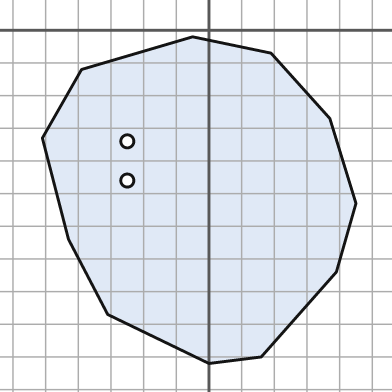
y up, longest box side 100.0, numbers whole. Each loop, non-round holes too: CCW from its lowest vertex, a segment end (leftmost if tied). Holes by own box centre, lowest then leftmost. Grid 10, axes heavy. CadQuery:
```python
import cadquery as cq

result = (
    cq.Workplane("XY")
    .moveTo(0.0, -102.0)
    .lineTo(16.0, -100.0)
    .lineTo(39.0, -74.0)
    .lineTo(45.0, -53.0)
    .lineTo(37.0, -27.0)
    .lineTo(19.0, -7.0)
    .lineTo(-5.0, -2.0)
    .lineTo(-39.0, -12.0)
    .lineTo(-51.0, -33.0)
    .lineTo(-43.0, -64.0)
    .lineTo(-31.0, -87.0)
    .close()
    .moveTo(-25.0, -46.0)
    .circle(2.0)
    .moveTo(-25.0, -34.0)
    .circle(2.0)
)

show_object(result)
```